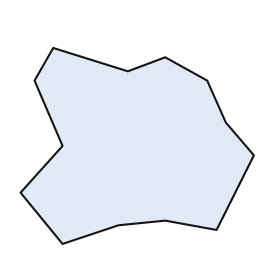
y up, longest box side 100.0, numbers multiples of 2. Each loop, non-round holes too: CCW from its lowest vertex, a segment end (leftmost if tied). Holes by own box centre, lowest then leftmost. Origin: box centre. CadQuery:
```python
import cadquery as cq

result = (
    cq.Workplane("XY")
    .moveTo(-32.0, -42.0)
    .lineTo(-8.0, -34.0)
    .lineTo(12.0, -32.0)
    .lineTo(34.0, -36.0)
    .lineTo(50.0, -4.0)
    .lineTo(38.0, 10.0)
    .lineTo(30.0, 28.0)
    .lineTo(12.0, 38.0)
    .lineTo(-4.0, 32.0)
    .lineTo(-36.0, 42.0)
    .lineTo(-44.0, 28.0)
    .lineTo(-32.0, 0.0)
    .lineTo(-50.0, -20.0)
    .close()
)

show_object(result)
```